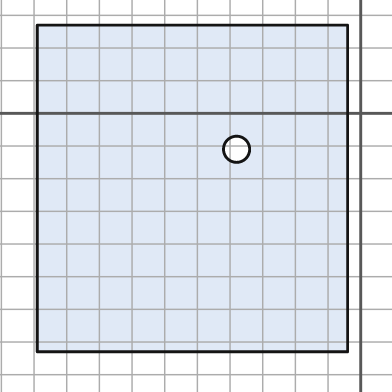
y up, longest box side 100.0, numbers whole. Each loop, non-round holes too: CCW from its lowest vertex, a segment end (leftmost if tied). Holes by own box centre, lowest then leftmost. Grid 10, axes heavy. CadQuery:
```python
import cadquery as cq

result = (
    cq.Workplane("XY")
    .moveTo(-99.0, -73.0)
    .lineTo(-4.0, -73.0)
    .lineTo(-4.0, 27.0)
    .lineTo(-99.0, 27.0)
    .close()
    .moveTo(-38.0, -11.0)
    .circle(4.0)
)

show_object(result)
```